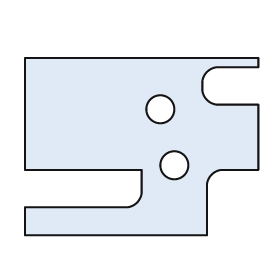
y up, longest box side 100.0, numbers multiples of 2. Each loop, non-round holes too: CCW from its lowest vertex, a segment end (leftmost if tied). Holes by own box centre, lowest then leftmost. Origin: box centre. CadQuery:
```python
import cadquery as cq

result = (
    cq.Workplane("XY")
    .moveTo(-50.0, -38.0)
    .lineTo(28.0, -38.0)
    .lineTo(28.0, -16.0)
    .threePointArc((30.0, -12.0), (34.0, -10.0))
    .lineTo(50.0, -10.0)
    .lineTo(50.0, 18.0)
    .lineTo(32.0, 18.0)
    .threePointArc((28.0, 20.0), (26.0, 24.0))
    .lineTo(26.0, 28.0)
    .threePointArc((28.0, 32.0), (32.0, 34.0))
    .lineTo(50.0, 34.0)
    .lineTo(50.0, 38.0)
    .lineTo(-50.0, 38.0)
    .lineTo(-50.0, -10.0)
    .lineTo(0.0, -10.0)
    .lineTo(0.0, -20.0)
    .threePointArc((-2.0, -24.0), (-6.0, -26.0))
    .lineTo(-50.0, -26.0)
    .close()
    .moveTo(14.0, -8.0)
    .circle(6.0)
    .moveTo(8.0, 16.0)
    .circle(6.0)
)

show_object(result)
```